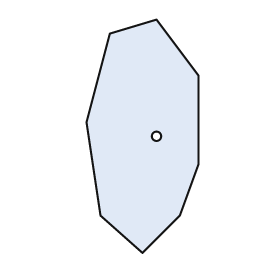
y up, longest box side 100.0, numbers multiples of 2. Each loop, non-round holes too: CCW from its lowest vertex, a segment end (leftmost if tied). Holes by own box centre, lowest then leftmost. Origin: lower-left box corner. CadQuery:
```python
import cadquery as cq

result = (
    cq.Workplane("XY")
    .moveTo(24.0, 0.0)
    .lineTo(40.0, 16.0)
    .lineTo(48.0, 38.0)
    .lineTo(48.0, 76.0)
    .lineTo(30.0, 100.0)
    .lineTo(10.0, 94.0)
    .lineTo(0.0, 56.0)
    .lineTo(6.0, 16.0)
    .close()
    .moveTo(30.0, 50.0)
    .circle(2.0)
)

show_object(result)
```